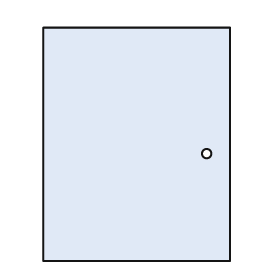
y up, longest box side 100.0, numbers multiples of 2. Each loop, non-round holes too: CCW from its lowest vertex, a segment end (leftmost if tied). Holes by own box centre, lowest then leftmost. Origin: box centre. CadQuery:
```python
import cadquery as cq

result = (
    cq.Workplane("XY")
    .moveTo(-40.0, -50.0)
    .lineTo(40.0, -50.0)
    .lineTo(40.0, 50.0)
    .lineTo(-40.0, 50.0)
    .close()
    .moveTo(30.0, -4.0)
    .circle(2.0)
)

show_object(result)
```